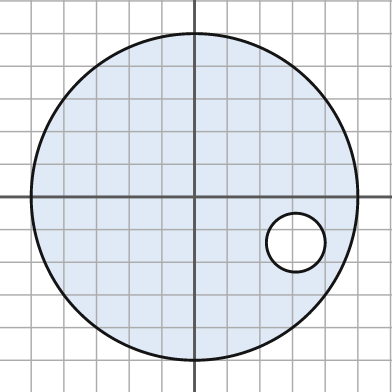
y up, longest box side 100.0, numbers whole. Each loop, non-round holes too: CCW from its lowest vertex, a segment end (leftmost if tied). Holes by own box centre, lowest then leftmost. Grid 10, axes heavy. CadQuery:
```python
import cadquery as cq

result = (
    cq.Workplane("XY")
    .moveTo(0.0, 0.0)
    .circle(50.0)
    .moveTo(31.0, -14.0)
    .circle(9.0)
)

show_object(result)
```